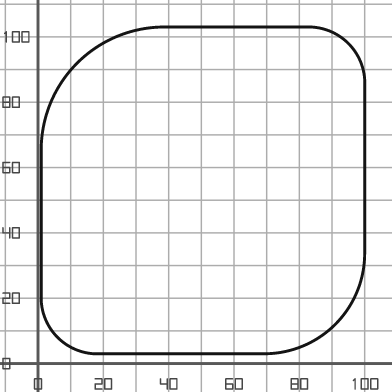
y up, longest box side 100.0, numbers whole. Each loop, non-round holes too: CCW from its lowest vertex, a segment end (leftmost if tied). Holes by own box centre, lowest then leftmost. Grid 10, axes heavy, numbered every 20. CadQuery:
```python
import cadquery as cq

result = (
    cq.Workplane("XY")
    .moveTo(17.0, 3.0)
    .lineTo(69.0, 3.0)
    .threePointArc((91.0, 12.0), (100.0, 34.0))
    .lineTo(100.0, 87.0)
    .threePointArc((95.0, 98.0), (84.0, 103.0))
    .lineTo(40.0, 103.0)
    .threePointArc((12.0, 92.0), (1.0, 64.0))
    .lineTo(1.0, 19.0)
    .threePointArc((6.0, 8.0), (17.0, 3.0))
    .close()
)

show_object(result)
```